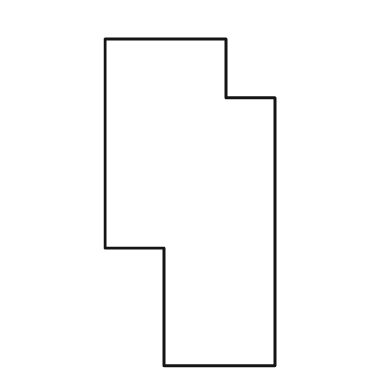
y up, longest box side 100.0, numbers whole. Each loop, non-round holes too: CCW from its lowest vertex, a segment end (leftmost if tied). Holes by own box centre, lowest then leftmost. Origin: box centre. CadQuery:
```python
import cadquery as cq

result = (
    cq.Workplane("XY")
    .moveTo(-8.0, -50.0)
    .lineTo(26.0, -50.0)
    .lineTo(26.0, 32.0)
    .lineTo(11.0, 32.0)
    .lineTo(11.0, 50.0)
    .lineTo(-26.0, 50.0)
    .lineTo(-26.0, -14.0)
    .lineTo(-8.0, -14.0)
    .close()
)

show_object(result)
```